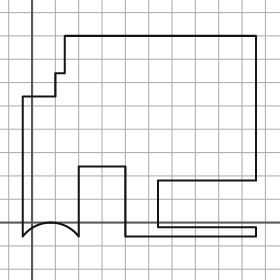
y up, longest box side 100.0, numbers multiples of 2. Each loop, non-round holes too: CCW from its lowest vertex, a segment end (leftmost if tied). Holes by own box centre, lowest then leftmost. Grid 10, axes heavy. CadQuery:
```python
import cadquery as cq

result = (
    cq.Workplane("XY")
    .moveTo(-4.0, -6.0)
    .threePointArc((8.0, 0.0), (20.0, -6.0))
    .lineTo(20.0, 24.0)
    .lineTo(40.0, 24.0)
    .lineTo(40.0, -6.0)
    .lineTo(96.0, -6.0)
    .lineTo(96.0, -2.0)
    .lineTo(54.0, -2.0)
    .lineTo(54.0, 18.0)
    .lineTo(96.0, 18.0)
    .lineTo(96.0, 80.0)
    .lineTo(14.0, 80.0)
    .lineTo(14.0, 64.0)
    .lineTo(10.0, 64.0)
    .lineTo(10.0, 54.0)
    .lineTo(-4.0, 54.0)
    .close()
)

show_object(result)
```